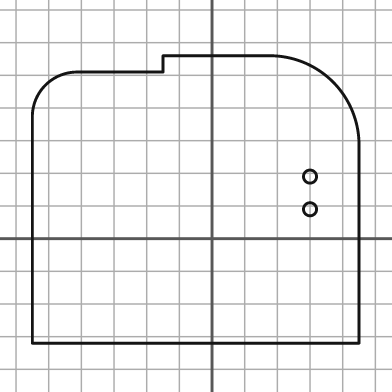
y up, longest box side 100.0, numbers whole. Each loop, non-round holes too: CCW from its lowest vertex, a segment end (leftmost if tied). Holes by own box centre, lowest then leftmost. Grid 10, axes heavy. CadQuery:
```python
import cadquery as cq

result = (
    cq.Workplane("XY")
    .moveTo(-55.0, -32.0)
    .lineTo(45.0, -32.0)
    .lineTo(45.0, 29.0)
    .threePointArc((37.0, 48.0), (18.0, 56.0))
    .lineTo(-15.0, 56.0)
    .lineTo(-15.0, 51.0)
    .lineTo(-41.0, 51.0)
    .threePointArc((-51.0, 47.0), (-55.0, 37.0))
    .close()
    .moveTo(30.0, 9.0)
    .circle(2.0)
    .moveTo(30.0, 19.0)
    .circle(2.0)
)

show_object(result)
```